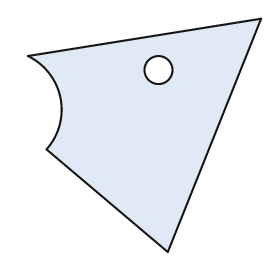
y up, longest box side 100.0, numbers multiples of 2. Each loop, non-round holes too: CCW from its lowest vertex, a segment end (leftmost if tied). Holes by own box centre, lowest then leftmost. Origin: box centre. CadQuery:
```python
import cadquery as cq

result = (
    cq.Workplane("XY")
    .moveTo(10.0, -50.0)
    .lineTo(50.0, 50.0)
    .lineTo(-50.0, 34.0)
    .threePointArc((-36.0, 16.0), (-42.0, -6.0))
    .close()
    .moveTo(6.0, 28.0)
    .circle(6.0)
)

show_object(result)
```